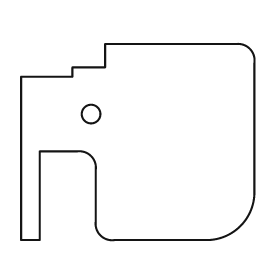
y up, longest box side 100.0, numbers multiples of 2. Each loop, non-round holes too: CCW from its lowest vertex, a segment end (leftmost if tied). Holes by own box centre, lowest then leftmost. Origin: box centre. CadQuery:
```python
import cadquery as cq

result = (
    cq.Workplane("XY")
    .moveTo(-50.0, -42.0)
    .lineTo(-42.0, -42.0)
    .lineTo(-42.0, -4.0)
    .lineTo(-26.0, -4.0)
    .threePointArc((-20.0, -6.0), (-18.0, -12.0))
    .lineTo(-18.0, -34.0)
    .threePointArc((-16.0, -40.0), (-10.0, -42.0))
    .lineTo(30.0, -42.0)
    .threePointArc((44.0, -36.0), (50.0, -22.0))
    .lineTo(50.0, 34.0)
    .threePointArc((48.0, 40.0), (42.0, 42.0))
    .lineTo(-14.0, 42.0)
    .lineTo(-14.0, 32.0)
    .lineTo(-28.0, 32.0)
    .lineTo(-28.0, 28.0)
    .lineTo(-50.0, 28.0)
    .close()
    .moveTo(-20.0, 12.0)
    .circle(4.0)
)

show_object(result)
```